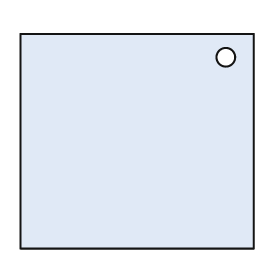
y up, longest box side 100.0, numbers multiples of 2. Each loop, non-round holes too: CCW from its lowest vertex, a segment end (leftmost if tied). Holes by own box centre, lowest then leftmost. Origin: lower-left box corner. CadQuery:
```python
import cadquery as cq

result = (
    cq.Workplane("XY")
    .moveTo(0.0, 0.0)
    .lineTo(100.0, 0.0)
    .lineTo(100.0, 92.0)
    .lineTo(0.0, 92.0)
    .close()
    .moveTo(88.0, 82.0)
    .circle(4.0)
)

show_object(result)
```